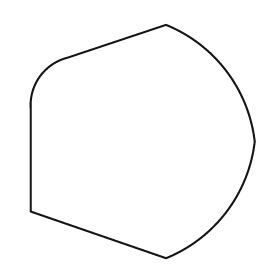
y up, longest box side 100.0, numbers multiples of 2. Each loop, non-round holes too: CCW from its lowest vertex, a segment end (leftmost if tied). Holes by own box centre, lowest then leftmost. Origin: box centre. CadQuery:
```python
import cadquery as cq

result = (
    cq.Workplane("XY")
    .moveTo(10.0, -50.0)
    .threePointArc((36.0, -30.0), (48.0, 0.0))
    .threePointArc((36.0, 30.0), (10.0, 50.0))
    .lineTo(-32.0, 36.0)
    .threePointArc((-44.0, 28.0), (-48.0, 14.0))
    .lineTo(-48.0, -30.0)
    .close()
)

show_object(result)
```